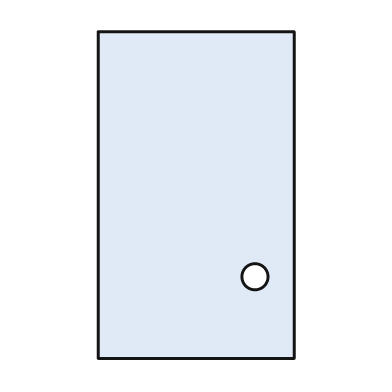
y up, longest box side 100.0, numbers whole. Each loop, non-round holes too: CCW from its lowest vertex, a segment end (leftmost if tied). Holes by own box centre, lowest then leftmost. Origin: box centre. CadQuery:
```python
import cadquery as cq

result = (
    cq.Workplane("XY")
    .moveTo(-30.0, -50.0)
    .lineTo(30.0, -50.0)
    .lineTo(30.0, 50.0)
    .lineTo(-30.0, 50.0)
    .close()
    .moveTo(18.0, -25.0)
    .circle(4.0)
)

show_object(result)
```